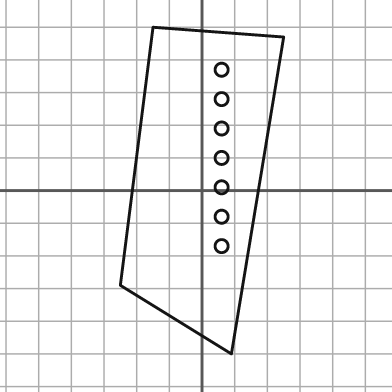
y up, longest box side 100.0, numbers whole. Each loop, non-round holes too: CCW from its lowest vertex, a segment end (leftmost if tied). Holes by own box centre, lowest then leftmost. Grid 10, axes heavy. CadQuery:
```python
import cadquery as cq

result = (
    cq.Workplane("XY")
    .moveTo(9.0, -50.0)
    .lineTo(25.0, 47.0)
    .lineTo(-15.0, 50.0)
    .lineTo(-25.0, -29.0)
    .close()
    .moveTo(6.0, -17.0)
    .circle(2.0)
    .moveTo(6.0, -8.0)
    .circle(2.0)
    .moveTo(6.0, 1.0)
    .circle(2.0)
    .moveTo(6.0, 10.0)
    .circle(2.0)
    .moveTo(6.0, 19.0)
    .circle(2.0)
    .moveTo(6.0, 28.0)
    .circle(2.0)
    .moveTo(6.0, 37.0)
    .circle(2.0)
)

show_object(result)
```